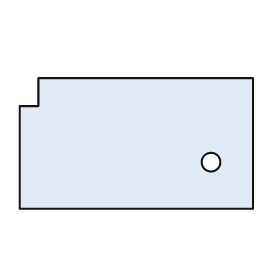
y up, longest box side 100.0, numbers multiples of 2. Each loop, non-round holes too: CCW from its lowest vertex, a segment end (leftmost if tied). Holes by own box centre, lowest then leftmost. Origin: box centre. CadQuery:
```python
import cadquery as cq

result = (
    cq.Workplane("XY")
    .moveTo(-50.0, -28.0)
    .lineTo(50.0, -28.0)
    .lineTo(50.0, 28.0)
    .lineTo(-42.0, 28.0)
    .lineTo(-42.0, 16.0)
    .lineTo(-50.0, 16.0)
    .close()
    .moveTo(32.0, -8.0)
    .circle(4.0)
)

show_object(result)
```